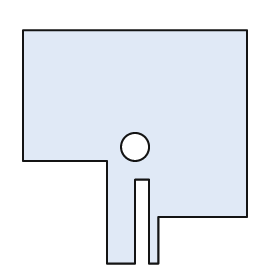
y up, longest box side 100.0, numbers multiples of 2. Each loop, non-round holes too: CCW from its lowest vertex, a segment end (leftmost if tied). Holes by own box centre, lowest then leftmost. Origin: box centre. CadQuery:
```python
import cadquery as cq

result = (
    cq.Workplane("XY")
    .moveTo(-12.0, -50.0)
    .lineTo(0.0, -50.0)
    .lineTo(0.0, -14.0)
    .lineTo(6.0, -14.0)
    .lineTo(6.0, -50.0)
    .lineTo(10.0, -50.0)
    .lineTo(10.0, -30.0)
    .lineTo(48.0, -30.0)
    .lineTo(48.0, 50.0)
    .lineTo(-48.0, 50.0)
    .lineTo(-48.0, -6.0)
    .lineTo(-12.0, -6.0)
    .close()
    .moveTo(0.0, 0.0)
    .circle(6.0)
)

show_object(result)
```